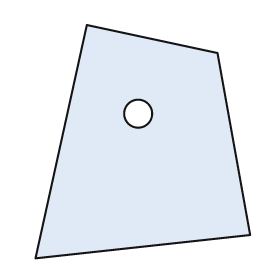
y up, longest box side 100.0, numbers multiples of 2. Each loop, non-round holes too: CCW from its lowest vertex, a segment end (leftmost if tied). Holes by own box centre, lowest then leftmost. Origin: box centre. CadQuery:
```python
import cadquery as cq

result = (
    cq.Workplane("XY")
    .moveTo(-46.0, -50.0)
    .lineTo(46.0, -40.0)
    .lineTo(32.0, 38.0)
    .lineTo(-24.0, 50.0)
    .close()
    .moveTo(-2.0, 12.0)
    .circle(6.0)
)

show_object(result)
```